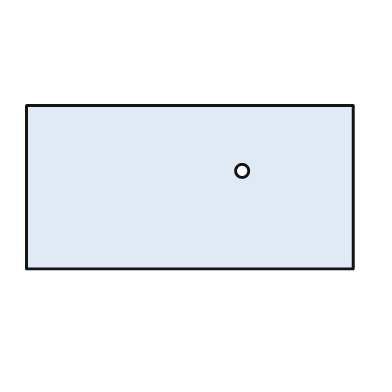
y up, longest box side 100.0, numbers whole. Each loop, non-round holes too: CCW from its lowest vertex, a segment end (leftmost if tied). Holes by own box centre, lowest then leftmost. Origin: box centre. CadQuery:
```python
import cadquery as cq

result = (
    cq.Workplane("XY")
    .moveTo(-50.0, -25.0)
    .lineTo(50.0, -25.0)
    .lineTo(50.0, 25.0)
    .lineTo(-50.0, 25.0)
    .close()
    .moveTo(16.0, 5.0)
    .circle(2.0)
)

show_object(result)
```